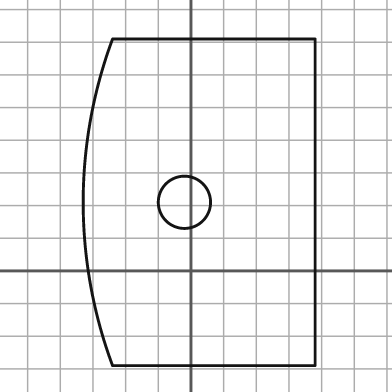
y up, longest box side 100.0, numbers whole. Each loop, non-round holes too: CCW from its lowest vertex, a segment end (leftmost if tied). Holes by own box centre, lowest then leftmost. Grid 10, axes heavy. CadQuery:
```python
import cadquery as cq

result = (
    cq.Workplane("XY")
    .moveTo(-24.0, -29.0)
    .lineTo(38.0, -29.0)
    .lineTo(38.0, 71.0)
    .lineTo(-24.0, 71.0)
    .threePointArc((-33.0, 21.0), (-24.0, -29.0))
    .close()
    .moveTo(-2.0, 21.0)
    .circle(8.0)
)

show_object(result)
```